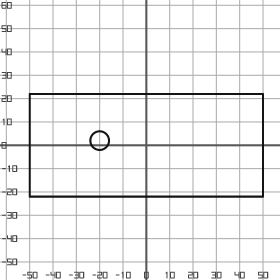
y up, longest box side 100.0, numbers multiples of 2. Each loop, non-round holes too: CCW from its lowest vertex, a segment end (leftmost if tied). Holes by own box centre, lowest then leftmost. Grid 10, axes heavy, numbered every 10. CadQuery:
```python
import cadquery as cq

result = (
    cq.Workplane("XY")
    .moveTo(-50.0, -22.0)
    .lineTo(50.0, -22.0)
    .lineTo(50.0, 22.0)
    .lineTo(-50.0, 22.0)
    .close()
    .moveTo(-20.0, 2.0)
    .circle(4.0)
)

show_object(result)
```